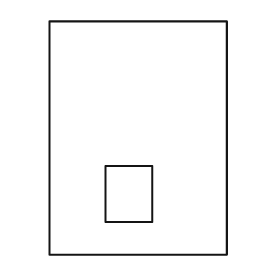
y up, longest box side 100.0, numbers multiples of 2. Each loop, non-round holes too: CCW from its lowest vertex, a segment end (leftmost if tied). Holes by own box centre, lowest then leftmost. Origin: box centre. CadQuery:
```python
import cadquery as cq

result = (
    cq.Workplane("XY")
    .moveTo(-38.0, -50.0)
    .lineTo(38.0, -50.0)
    .lineTo(38.0, 50.0)
    .lineTo(-38.0, 50.0)
    .close()
    .moveTo(-14.0, -36.0)
    .lineTo(6.0, -36.0)
    .lineTo(6.0, -12.0)
    .lineTo(-14.0, -12.0)
    .close()
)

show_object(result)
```